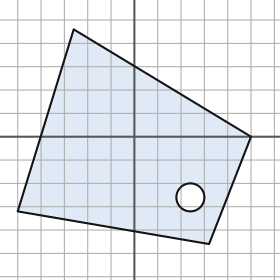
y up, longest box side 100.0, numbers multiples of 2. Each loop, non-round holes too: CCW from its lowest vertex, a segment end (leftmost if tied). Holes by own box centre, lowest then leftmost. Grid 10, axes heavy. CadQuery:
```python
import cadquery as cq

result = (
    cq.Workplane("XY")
    .moveTo(32.0, -46.0)
    .lineTo(50.0, 0.0)
    .lineTo(-26.0, 46.0)
    .lineTo(-50.0, -32.0)
    .close()
    .moveTo(24.0, -26.0)
    .circle(6.0)
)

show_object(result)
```